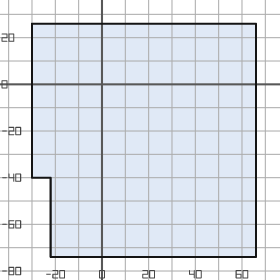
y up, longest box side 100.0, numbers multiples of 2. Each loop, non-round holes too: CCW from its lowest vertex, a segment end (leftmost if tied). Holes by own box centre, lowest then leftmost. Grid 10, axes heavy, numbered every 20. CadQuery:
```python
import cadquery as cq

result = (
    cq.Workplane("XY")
    .moveTo(-22.0, -74.0)
    .lineTo(66.0, -74.0)
    .lineTo(66.0, 26.0)
    .lineTo(-30.0, 26.0)
    .lineTo(-30.0, -40.0)
    .lineTo(-22.0, -40.0)
    .close()
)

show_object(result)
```